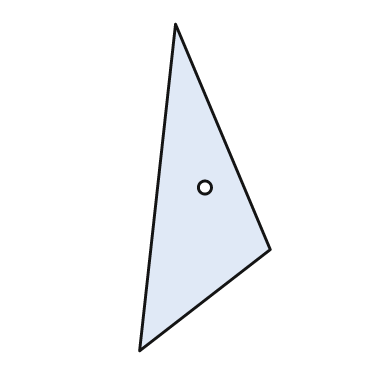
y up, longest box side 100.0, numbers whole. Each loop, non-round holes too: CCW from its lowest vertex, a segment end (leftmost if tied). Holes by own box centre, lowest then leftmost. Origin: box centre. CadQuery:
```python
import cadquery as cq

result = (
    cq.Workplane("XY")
    .moveTo(-20.0, -50.0)
    .lineTo(20.0, -19.0)
    .lineTo(-9.0, 50.0)
    .close()
    .moveTo(0.0, 0.0)
    .circle(2.0)
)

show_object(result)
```